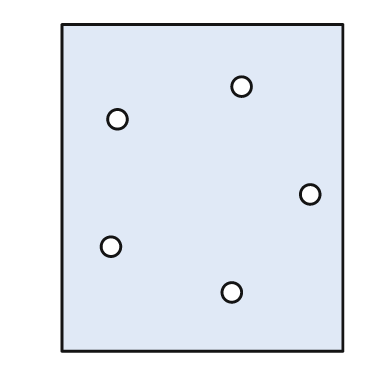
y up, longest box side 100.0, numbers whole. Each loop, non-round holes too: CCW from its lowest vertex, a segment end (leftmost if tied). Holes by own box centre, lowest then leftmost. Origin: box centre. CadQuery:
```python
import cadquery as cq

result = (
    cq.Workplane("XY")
    .moveTo(-43.0, -50.0)
    .lineTo(43.0, -50.0)
    .lineTo(43.0, 50.0)
    .lineTo(-43.0, 50.0)
    .close()
    .moveTo(9.0, -32.0)
    .circle(3.0)
    .moveTo(-28.0, -18.0)
    .circle(3.0)
    .moveTo(33.0, -2.0)
    .circle(3.0)
    .moveTo(-26.0, 21.0)
    .circle(3.0)
    .moveTo(12.0, 31.0)
    .circle(3.0)
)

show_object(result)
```